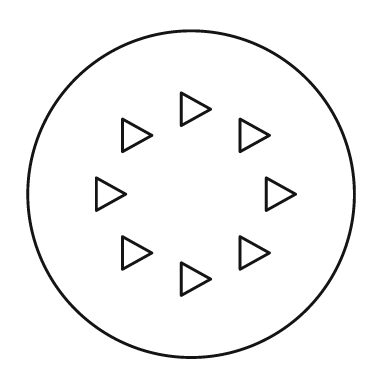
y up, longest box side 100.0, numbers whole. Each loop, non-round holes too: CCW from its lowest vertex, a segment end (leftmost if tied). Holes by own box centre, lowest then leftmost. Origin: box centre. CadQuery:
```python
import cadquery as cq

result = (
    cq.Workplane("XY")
    .moveTo(0.0, 0.0)
    .circle(50.0)
    .moveTo(-3.0, -31.0)
    .lineTo(6.0, -26.0)
    .lineTo(-3.0, -21.0)
    .close()
    .moveTo(-21.0, -23.0)
    .lineTo(-12.0, -18.0)
    .lineTo(-21.0, -13.0)
    .close()
    .moveTo(15.0, -23.0)
    .lineTo(24.0, -18.0)
    .lineTo(15.0, -13.0)
    .close()
    .moveTo(-29.0, -5.0)
    .lineTo(-20.0, 0.0)
    .lineTo(-29.0, 5.0)
    .close()
    .moveTo(23.0, -5.0)
    .lineTo(32.0, 0.0)
    .lineTo(23.0, 5.0)
    .close()
    .moveTo(-21.0, 13.0)
    .lineTo(-12.0, 18.0)
    .lineTo(-21.0, 23.0)
    .close()
    .moveTo(15.0, 13.0)
    .lineTo(24.0, 18.0)
    .lineTo(15.0, 23.0)
    .close()
    .moveTo(-3.0, 21.0)
    .lineTo(6.0, 26.0)
    .lineTo(-3.0, 31.0)
    .close()
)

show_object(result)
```